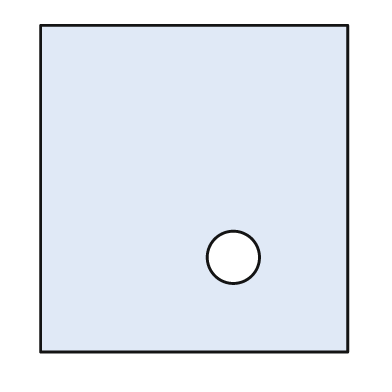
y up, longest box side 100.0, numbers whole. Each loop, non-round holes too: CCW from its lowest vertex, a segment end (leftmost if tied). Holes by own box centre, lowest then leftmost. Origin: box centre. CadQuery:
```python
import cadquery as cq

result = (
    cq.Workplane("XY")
    .moveTo(-47.0, -50.0)
    .lineTo(47.0, -50.0)
    .lineTo(47.0, 50.0)
    .lineTo(-47.0, 50.0)
    .close()
    .moveTo(12.0, -21.0)
    .circle(8.0)
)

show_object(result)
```